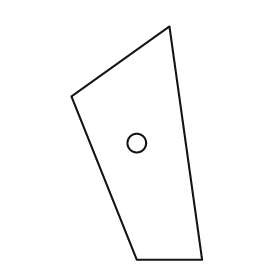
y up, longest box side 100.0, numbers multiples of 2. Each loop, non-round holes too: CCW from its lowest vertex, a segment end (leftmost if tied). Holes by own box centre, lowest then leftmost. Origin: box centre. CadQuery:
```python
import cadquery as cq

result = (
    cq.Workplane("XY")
    .moveTo(0.0, -50.0)
    .lineTo(28.0, -50.0)
    .lineTo(14.0, 50.0)
    .lineTo(-28.0, 20.0)
    .close()
    .moveTo(0.0, 0.0)
    .circle(4.0)
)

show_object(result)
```